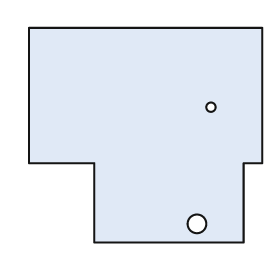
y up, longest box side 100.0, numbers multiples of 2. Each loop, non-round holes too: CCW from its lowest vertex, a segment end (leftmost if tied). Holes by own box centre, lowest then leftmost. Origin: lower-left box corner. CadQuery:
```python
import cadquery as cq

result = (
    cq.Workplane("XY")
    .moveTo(28.0, 0.0)
    .lineTo(92.0, 0.0)
    .lineTo(92.0, 34.0)
    .lineTo(100.0, 34.0)
    .lineTo(100.0, 92.0)
    .lineTo(0.0, 92.0)
    .lineTo(0.0, 34.0)
    .lineTo(28.0, 34.0)
    .close()
    .moveTo(72.0, 8.0)
    .circle(4.0)
    .moveTo(78.0, 58.0)
    .circle(2.0)
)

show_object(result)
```